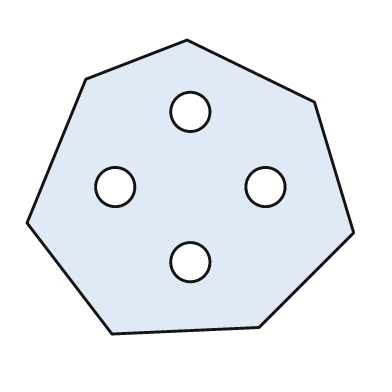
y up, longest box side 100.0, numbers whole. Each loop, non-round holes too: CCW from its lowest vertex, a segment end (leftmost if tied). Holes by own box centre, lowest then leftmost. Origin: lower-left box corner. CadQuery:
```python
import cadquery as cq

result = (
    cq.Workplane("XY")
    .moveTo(26.0, 0.0)
    .lineTo(71.0, 2.0)
    .lineTo(100.0, 31.0)
    .lineTo(88.0, 71.0)
    .lineTo(49.0, 90.0)
    .lineTo(18.0, 78.0)
    .lineTo(0.0, 34.0)
    .close()
    .moveTo(50.0, 22.0)
    .circle(6.0)
    .moveTo(27.0, 45.0)
    .circle(6.0)
    .moveTo(73.0, 45.0)
    .circle(6.0)
    .moveTo(50.0, 68.0)
    .circle(6.0)
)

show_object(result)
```